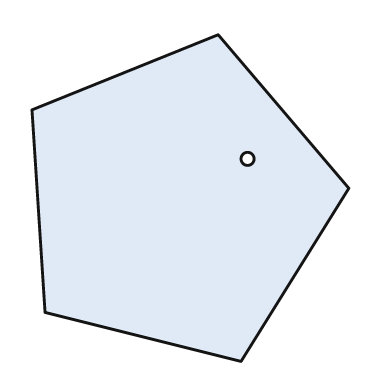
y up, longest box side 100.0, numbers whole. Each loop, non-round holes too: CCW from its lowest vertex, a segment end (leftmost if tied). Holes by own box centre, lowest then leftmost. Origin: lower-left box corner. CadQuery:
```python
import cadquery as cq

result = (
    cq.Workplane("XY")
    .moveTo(64.0, 0.0)
    .lineTo(97.0, 53.0)
    .lineTo(57.0, 100.0)
    .lineTo(0.0, 77.0)
    .lineTo(4.0, 15.0)
    .close()
    .moveTo(66.0, 62.0)
    .circle(2.0)
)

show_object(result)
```